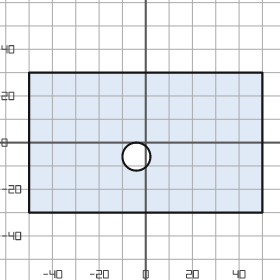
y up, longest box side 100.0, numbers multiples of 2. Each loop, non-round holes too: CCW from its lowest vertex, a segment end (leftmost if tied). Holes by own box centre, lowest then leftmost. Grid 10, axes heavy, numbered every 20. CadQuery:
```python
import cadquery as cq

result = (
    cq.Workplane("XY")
    .moveTo(-50.0, -30.0)
    .lineTo(50.0, -30.0)
    .lineTo(50.0, 30.0)
    .lineTo(-50.0, 30.0)
    .close()
    .moveTo(-4.0, -6.0)
    .circle(6.0)
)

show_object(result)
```